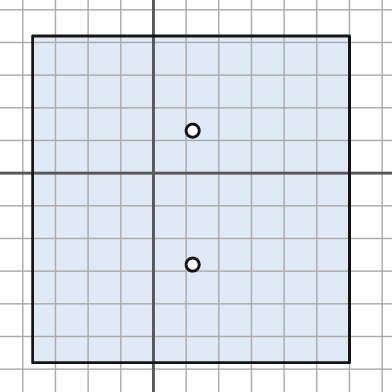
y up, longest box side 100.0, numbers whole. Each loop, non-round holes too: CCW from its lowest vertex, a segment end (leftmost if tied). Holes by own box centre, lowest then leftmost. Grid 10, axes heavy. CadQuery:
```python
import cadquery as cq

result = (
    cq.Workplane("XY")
    .moveTo(-37.0, -58.0)
    .lineTo(60.0, -58.0)
    .lineTo(60.0, 42.0)
    .lineTo(-37.0, 42.0)
    .close()
    .moveTo(12.0, -28.0)
    .circle(2.0)
    .moveTo(12.0, 13.0)
    .circle(2.0)
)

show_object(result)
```